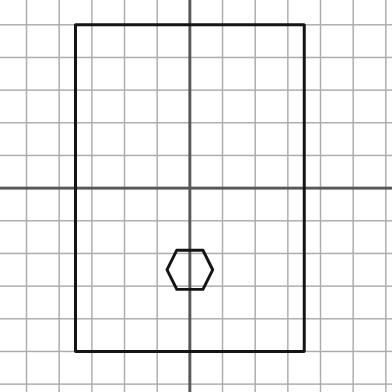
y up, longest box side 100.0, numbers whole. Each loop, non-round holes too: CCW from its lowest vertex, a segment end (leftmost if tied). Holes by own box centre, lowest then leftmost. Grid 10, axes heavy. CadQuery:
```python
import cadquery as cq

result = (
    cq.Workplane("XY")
    .moveTo(-35.0, -50.0)
    .lineTo(35.0, -50.0)
    .lineTo(35.0, 50.0)
    .lineTo(-35.0, 50.0)
    .close()
    .moveTo(-4.0, -31.0)
    .lineTo(4.0, -31.0)
    .lineTo(7.0, -25.0)
    .lineTo(4.0, -19.0)
    .lineTo(-4.0, -19.0)
    .lineTo(-7.0, -25.0)
    .close()
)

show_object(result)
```